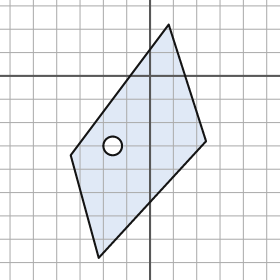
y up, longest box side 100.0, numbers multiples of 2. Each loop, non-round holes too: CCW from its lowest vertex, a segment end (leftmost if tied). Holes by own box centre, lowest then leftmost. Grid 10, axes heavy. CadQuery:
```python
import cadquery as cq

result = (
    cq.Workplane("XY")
    .moveTo(-22.0, -78.0)
    .lineTo(24.0, -28.0)
    .lineTo(8.0, 22.0)
    .lineTo(-34.0, -34.0)
    .close()
    .moveTo(-16.0, -30.0)
    .circle(4.0)
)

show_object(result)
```